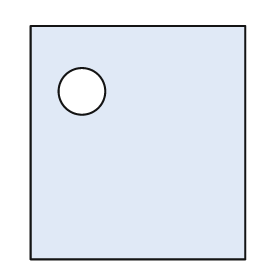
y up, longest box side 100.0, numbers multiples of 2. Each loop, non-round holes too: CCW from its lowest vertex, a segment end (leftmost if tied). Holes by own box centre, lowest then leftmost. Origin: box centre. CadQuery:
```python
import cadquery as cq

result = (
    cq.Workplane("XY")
    .moveTo(-46.0, -50.0)
    .lineTo(46.0, -50.0)
    .lineTo(46.0, 50.0)
    .lineTo(-46.0, 50.0)
    .close()
    .moveTo(-24.0, 22.0)
    .circle(10.0)
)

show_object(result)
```